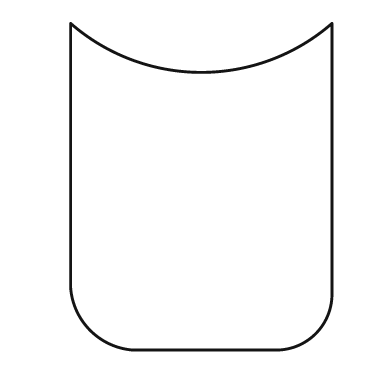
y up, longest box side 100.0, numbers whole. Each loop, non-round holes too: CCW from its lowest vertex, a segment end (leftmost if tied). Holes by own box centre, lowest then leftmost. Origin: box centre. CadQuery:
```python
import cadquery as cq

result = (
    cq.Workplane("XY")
    .moveTo(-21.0, -50.0)
    .lineTo(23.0, -50.0)
    .threePointArc((35.0, -45.0), (40.0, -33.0))
    .lineTo(40.0, 50.0)
    .threePointArc((0.0, 35.0), (-40.0, 50.0))
    .lineTo(-40.0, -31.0)
    .threePointArc((-34.0, -44.0), (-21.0, -50.0))
    .close()
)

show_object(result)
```